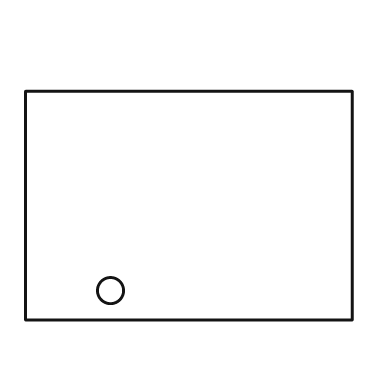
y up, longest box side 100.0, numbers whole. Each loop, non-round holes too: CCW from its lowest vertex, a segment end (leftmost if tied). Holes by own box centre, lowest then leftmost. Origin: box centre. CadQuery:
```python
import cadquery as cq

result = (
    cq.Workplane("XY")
    .moveTo(-50.0, -35.0)
    .lineTo(50.0, -35.0)
    .lineTo(50.0, 35.0)
    .lineTo(-50.0, 35.0)
    .close()
    .moveTo(-24.0, -26.0)
    .circle(4.0)
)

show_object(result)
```